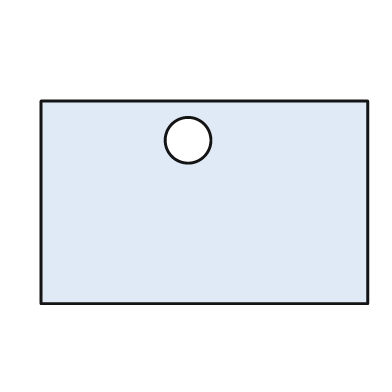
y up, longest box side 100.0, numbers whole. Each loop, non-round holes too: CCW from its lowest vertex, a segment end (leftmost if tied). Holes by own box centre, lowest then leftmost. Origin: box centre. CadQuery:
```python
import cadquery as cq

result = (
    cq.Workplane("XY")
    .moveTo(-50.0, -31.0)
    .lineTo(50.0, -31.0)
    .lineTo(50.0, 31.0)
    .lineTo(-50.0, 31.0)
    .close()
    .moveTo(-5.0, 19.0)
    .circle(7.0)
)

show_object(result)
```